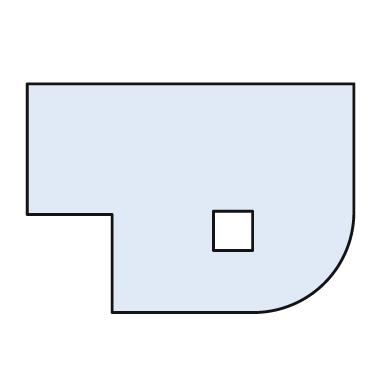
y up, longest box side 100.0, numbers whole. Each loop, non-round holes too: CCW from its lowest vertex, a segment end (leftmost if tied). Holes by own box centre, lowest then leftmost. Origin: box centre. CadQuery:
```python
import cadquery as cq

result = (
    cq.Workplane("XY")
    .moveTo(-24.0, -35.0)
    .lineTo(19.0, -35.0)
    .threePointArc((41.0, -26.0), (50.0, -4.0))
    .lineTo(50.0, 35.0)
    .lineTo(-50.0, 35.0)
    .lineTo(-50.0, -5.0)
    .lineTo(-24.0, -5.0)
    .close()
    .moveTo(7.0, -16.0)
    .lineTo(19.0, -16.0)
    .lineTo(19.0, -4.0)
    .lineTo(7.0, -4.0)
    .close()
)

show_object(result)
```